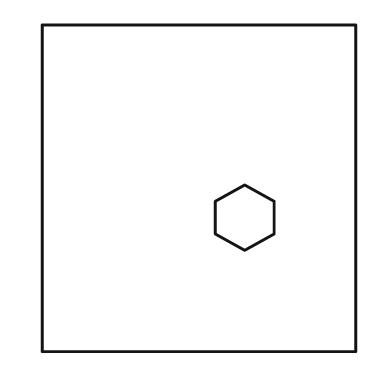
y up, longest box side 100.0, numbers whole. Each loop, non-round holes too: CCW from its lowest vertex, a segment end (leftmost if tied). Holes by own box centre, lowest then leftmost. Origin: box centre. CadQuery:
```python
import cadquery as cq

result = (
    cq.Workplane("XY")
    .moveTo(-48.0, -50.0)
    .lineTo(48.0, -50.0)
    .lineTo(48.0, 50.0)
    .lineTo(-48.0, 50.0)
    .close()
    .moveTo(14.0, -19.0)
    .lineTo(23.0, -14.0)
    .lineTo(23.0, -4.0)
    .lineTo(14.0, 1.0)
    .lineTo(5.0, -4.0)
    .lineTo(5.0, -14.0)
    .close()
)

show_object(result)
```